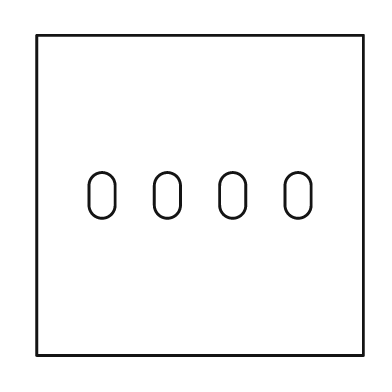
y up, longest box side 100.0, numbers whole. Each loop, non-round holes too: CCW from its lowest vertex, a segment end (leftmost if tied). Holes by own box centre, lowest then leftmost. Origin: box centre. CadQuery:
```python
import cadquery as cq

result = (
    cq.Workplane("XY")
    .moveTo(-50.0, -49.0)
    .lineTo(50.0, -49.0)
    .lineTo(50.0, 49.0)
    .lineTo(-50.0, 49.0)
    .close()
    .moveTo(-34.0, -3.0)
    .threePointArc((-30.0, -7.0), (-26.0, -3.0))
    .lineTo(-26.0, 3.0)
    .threePointArc((-30.0, 7.0), (-34.0, 3.0))
    .close()
    .moveTo(-14.0, -3.0)
    .threePointArc((-10.0, -7.0), (-6.0, -3.0))
    .lineTo(-6.0, 3.0)
    .threePointArc((-10.0, 7.0), (-14.0, 3.0))
    .close()
    .moveTo(6.0, -3.0)
    .threePointArc((10.0, -7.0), (14.0, -3.0))
    .lineTo(14.0, 3.0)
    .threePointArc((10.0, 7.0), (6.0, 3.0))
    .close()
    .moveTo(26.0, -3.0)
    .threePointArc((30.0, -7.0), (34.0, -3.0))
    .lineTo(34.0, 3.0)
    .threePointArc((30.0, 7.0), (26.0, 3.0))
    .close()
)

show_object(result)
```